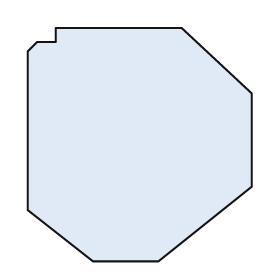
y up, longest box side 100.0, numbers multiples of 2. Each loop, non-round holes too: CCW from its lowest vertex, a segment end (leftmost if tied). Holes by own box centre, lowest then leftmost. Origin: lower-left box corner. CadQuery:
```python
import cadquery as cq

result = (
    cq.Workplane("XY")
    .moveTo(28.0, 0.0)
    .lineTo(56.0, 0.0)
    .lineTo(96.0, 32.0)
    .lineTo(96.0, 72.0)
    .lineTo(66.0, 100.0)
    .lineTo(12.0, 100.0)
    .lineTo(12.0, 94.0)
    .lineTo(4.0, 94.0)
    .lineTo(0.0, 90.0)
    .lineTo(0.0, 22.0)
    .close()
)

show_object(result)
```